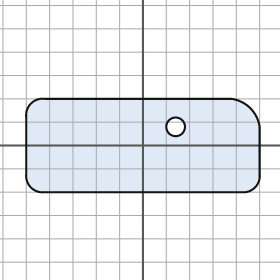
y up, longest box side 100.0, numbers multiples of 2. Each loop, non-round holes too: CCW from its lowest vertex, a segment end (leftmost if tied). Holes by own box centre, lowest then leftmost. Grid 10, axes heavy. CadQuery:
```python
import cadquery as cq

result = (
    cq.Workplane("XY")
    .moveTo(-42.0, -20.0)
    .lineTo(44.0, -20.0)
    .threePointArc((48.0, -18.0), (50.0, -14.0))
    .lineTo(50.0, 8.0)
    .threePointArc((46.0, 16.0), (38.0, 20.0))
    .lineTo(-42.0, 20.0)
    .threePointArc((-48.0, 18.0), (-50.0, 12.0))
    .lineTo(-50.0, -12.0)
    .threePointArc((-48.0, -18.0), (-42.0, -20.0))
    .close()
    .moveTo(14.0, 8.0)
    .circle(4.0)
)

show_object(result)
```